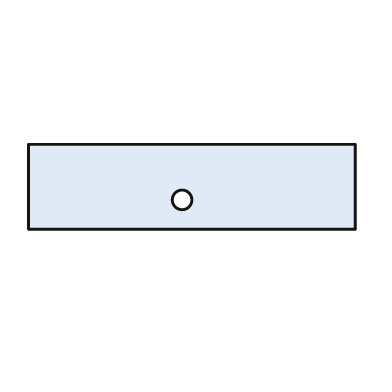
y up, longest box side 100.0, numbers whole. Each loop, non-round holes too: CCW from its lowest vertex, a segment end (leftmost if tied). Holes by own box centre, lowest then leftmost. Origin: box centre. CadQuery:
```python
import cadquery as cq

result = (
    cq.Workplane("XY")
    .moveTo(-50.0, -13.0)
    .lineTo(50.0, -13.0)
    .lineTo(50.0, 13.0)
    .lineTo(-50.0, 13.0)
    .close()
    .moveTo(-3.0, -4.0)
    .circle(3.0)
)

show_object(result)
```